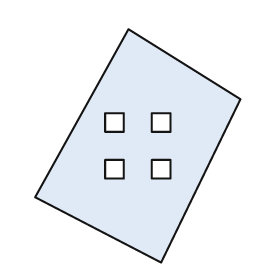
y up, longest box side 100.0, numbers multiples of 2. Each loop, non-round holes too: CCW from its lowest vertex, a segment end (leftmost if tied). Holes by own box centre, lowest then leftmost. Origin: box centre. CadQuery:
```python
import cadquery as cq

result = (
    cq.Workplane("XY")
    .moveTo(10.0, -50.0)
    .lineTo(44.0, 20.0)
    .lineTo(-4.0, 50.0)
    .lineTo(-44.0, -22.0)
    .close()
    .moveTo(-14.0, -14.0)
    .lineTo(-6.0, -14.0)
    .lineTo(-6.0, -6.0)
    .lineTo(-14.0, -6.0)
    .close()
    .moveTo(6.0, -14.0)
    .lineTo(14.0, -14.0)
    .lineTo(14.0, -6.0)
    .lineTo(6.0, -6.0)
    .close()
    .moveTo(-14.0, 6.0)
    .lineTo(-6.0, 6.0)
    .lineTo(-6.0, 14.0)
    .lineTo(-14.0, 14.0)
    .close()
    .moveTo(6.0, 6.0)
    .lineTo(14.0, 6.0)
    .lineTo(14.0, 14.0)
    .lineTo(6.0, 14.0)
    .close()
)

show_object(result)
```